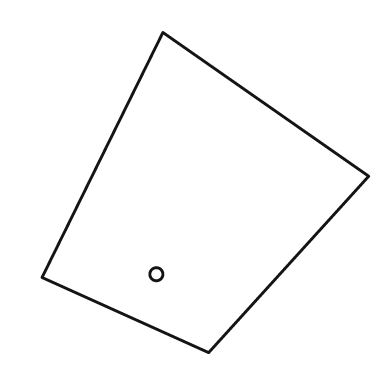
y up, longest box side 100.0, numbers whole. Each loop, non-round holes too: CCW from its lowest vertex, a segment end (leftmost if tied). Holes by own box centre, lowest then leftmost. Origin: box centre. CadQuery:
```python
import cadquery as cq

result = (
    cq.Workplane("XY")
    .moveTo(1.0, -49.0)
    .lineTo(50.0, 5.0)
    .lineTo(-13.0, 49.0)
    .lineTo(-50.0, -26.0)
    .close()
    .moveTo(-15.0, -25.0)
    .circle(2.0)
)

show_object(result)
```